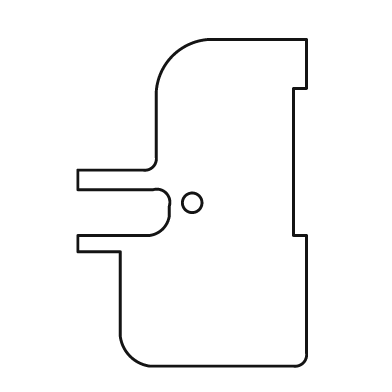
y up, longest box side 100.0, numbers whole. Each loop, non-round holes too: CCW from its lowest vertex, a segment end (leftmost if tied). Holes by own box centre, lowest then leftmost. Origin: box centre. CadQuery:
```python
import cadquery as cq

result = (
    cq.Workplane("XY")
    .moveTo(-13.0, -50.0)
    .lineTo(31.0, -50.0)
    .threePointArc((34.0, -49.0), (35.0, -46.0))
    .lineTo(35.0, -10.0)
    .lineTo(31.0, -10.0)
    .lineTo(31.0, 35.0)
    .lineTo(35.0, 35.0)
    .lineTo(35.0, 50.0)
    .lineTo(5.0, 50.0)
    .threePointArc((-6.0, 45.0), (-11.0, 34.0))
    .lineTo(-11.0, 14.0)
    .threePointArc((-12.0, 11.0), (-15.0, 10.0))
    .lineTo(-35.0, 10.0)
    .lineTo(-35.0, 4.0)
    .lineTo(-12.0, 4.0)
    .threePointArc((-8.0, 3.0), (-7.0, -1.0))
    .lineTo(-7.0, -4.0)
    .threePointArc((-9.0, -8.0), (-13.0, -10.0))
    .lineTo(-35.0, -10.0)
    .lineTo(-35.0, -15.0)
    .lineTo(-22.0, -15.0)
    .lineTo(-22.0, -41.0)
    .threePointArc((-19.0, -47.0), (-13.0, -50.0))
    .close()
    .moveTo(0.0, 0.0)
    .circle(3.0)
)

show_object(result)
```